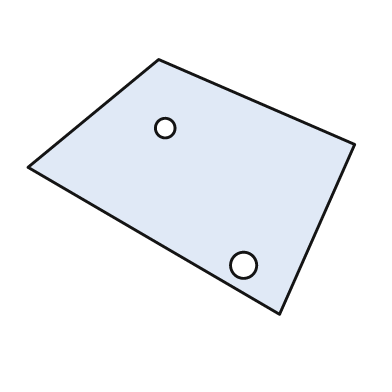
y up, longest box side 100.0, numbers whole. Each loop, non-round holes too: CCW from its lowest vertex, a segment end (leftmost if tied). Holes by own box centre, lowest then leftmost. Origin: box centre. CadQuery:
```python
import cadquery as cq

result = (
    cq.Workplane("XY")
    .moveTo(27.0, -39.0)
    .lineTo(50.0, 13.0)
    .lineTo(-10.0, 39.0)
    .lineTo(-50.0, 6.0)
    .close()
    .moveTo(16.0, -24.0)
    .circle(4.0)
    .moveTo(-8.0, 18.0)
    .circle(3.0)
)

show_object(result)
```